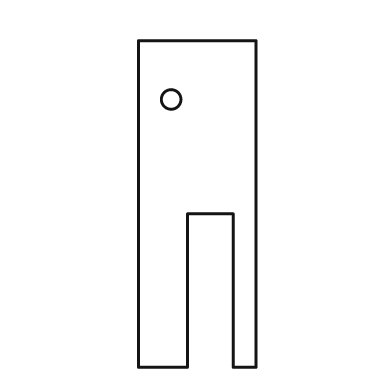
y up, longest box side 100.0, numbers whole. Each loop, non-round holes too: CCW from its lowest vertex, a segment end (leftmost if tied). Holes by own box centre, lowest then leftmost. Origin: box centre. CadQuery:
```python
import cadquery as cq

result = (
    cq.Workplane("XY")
    .moveTo(-18.0, -50.0)
    .lineTo(-3.0, -50.0)
    .lineTo(-3.0, -3.0)
    .lineTo(11.0, -3.0)
    .lineTo(11.0, -50.0)
    .lineTo(18.0, -50.0)
    .lineTo(18.0, 50.0)
    .lineTo(-18.0, 50.0)
    .close()
    .moveTo(-8.0, 32.0)
    .circle(3.0)
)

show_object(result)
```